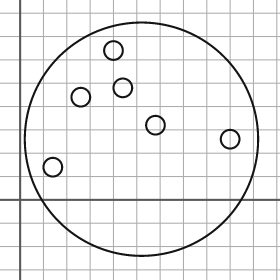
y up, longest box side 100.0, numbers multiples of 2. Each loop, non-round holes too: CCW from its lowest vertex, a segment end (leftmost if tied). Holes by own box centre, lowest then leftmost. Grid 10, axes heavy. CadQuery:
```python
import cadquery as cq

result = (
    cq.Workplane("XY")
    .moveTo(52.0, 26.0)
    .circle(50.0)
    .moveTo(14.0, 14.0)
    .circle(4.0)
    .moveTo(90.0, 26.0)
    .circle(4.0)
    .moveTo(58.0, 32.0)
    .circle(4.0)
    .moveTo(26.0, 44.0)
    .circle(4.0)
    .moveTo(44.0, 48.0)
    .circle(4.0)
    .moveTo(40.0, 64.0)
    .circle(4.0)
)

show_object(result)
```